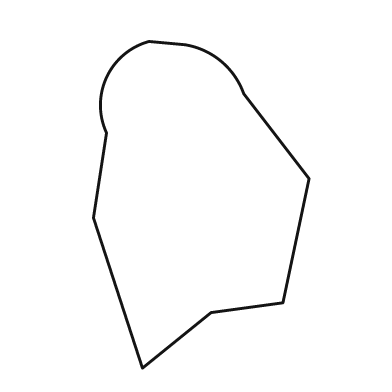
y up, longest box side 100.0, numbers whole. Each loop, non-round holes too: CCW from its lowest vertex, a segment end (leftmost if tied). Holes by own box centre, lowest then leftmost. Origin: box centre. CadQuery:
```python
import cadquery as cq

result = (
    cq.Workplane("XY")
    .moveTo(-18.0, -50.0)
    .lineTo(3.0, -33.0)
    .lineTo(25.0, -30.0)
    .lineTo(33.0, 8.0)
    .lineTo(13.0, 34.0)
    .threePointArc((6.0, 44.0), (-5.0, 49.0))
    .lineTo(-16.0, 50.0)
    .threePointArc((-29.0, 39.0), (-29.0, 22.0))
    .lineTo(-33.0, -4.0)
    .close()
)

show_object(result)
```